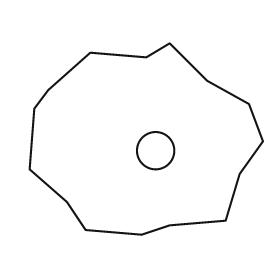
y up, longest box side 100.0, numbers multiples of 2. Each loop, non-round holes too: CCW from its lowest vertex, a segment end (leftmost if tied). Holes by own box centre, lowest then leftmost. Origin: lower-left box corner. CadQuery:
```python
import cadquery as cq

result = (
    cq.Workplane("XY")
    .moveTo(48.0, 0.0)
    .lineTo(60.0, 4.0)
    .lineTo(84.0, 6.0)
    .lineTo(90.0, 26.0)
    .lineTo(100.0, 40.0)
    .lineTo(94.0, 56.0)
    .lineTo(76.0, 66.0)
    .lineTo(60.0, 82.0)
    .lineTo(50.0, 76.0)
    .lineTo(26.0, 78.0)
    .lineTo(8.0, 62.0)
    .lineTo(2.0, 54.0)
    .lineTo(0.0, 28.0)
    .lineTo(16.0, 14.0)
    .lineTo(24.0, 2.0)
    .close()
    .moveTo(54.0, 36.0)
    .circle(8.0)
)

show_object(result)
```